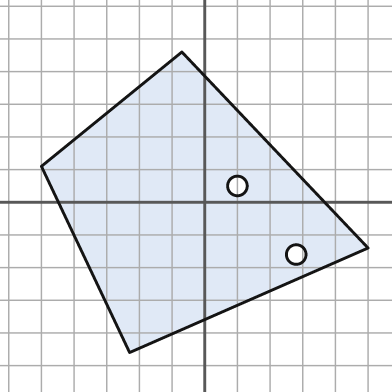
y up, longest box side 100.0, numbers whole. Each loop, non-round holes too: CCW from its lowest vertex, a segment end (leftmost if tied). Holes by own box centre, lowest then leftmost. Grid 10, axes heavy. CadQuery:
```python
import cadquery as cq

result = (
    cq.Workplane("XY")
    .moveTo(-23.0, -46.0)
    .lineTo(50.0, -14.0)
    .lineTo(-7.0, 46.0)
    .lineTo(-50.0, 11.0)
    .close()
    .moveTo(28.0, -16.0)
    .circle(3.0)
    .moveTo(10.0, 5.0)
    .circle(3.0)
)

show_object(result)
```